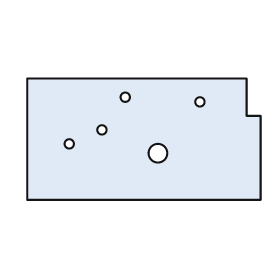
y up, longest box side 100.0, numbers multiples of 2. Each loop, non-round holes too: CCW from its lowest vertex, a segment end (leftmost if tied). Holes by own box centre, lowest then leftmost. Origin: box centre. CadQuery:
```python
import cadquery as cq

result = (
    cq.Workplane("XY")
    .moveTo(-50.0, -26.0)
    .lineTo(50.0, -26.0)
    .lineTo(50.0, 10.0)
    .lineTo(44.0, 10.0)
    .lineTo(44.0, 26.0)
    .lineTo(-50.0, 26.0)
    .close()
    .moveTo(6.0, -6.0)
    .circle(4.0)
    .moveTo(-32.0, -2.0)
    .circle(2.0)
    .moveTo(-18.0, 4.0)
    .circle(2.0)
    .moveTo(24.0, 16.0)
    .circle(2.0)
    .moveTo(-8.0, 18.0)
    .circle(2.0)
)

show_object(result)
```